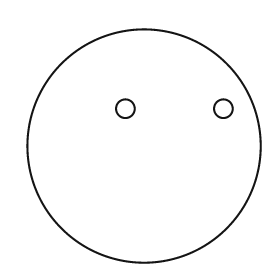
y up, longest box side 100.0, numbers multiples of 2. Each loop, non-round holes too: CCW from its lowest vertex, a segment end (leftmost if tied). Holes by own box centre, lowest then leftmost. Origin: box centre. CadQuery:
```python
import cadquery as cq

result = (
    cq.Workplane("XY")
    .moveTo(0.0, 0.0)
    .circle(50.0)
    .moveTo(-8.0, 16.0)
    .circle(4.0)
    .moveTo(34.0, 16.0)
    .circle(4.0)
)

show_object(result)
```